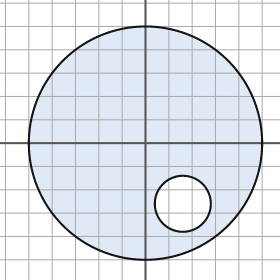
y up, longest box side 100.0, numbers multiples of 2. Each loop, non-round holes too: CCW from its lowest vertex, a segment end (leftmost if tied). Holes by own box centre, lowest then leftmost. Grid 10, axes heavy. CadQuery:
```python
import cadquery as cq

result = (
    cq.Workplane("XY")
    .moveTo(0.0, 0.0)
    .circle(50.0)
    .moveTo(16.0, -26.0)
    .circle(12.0)
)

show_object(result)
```